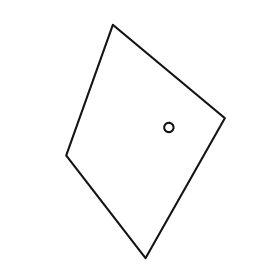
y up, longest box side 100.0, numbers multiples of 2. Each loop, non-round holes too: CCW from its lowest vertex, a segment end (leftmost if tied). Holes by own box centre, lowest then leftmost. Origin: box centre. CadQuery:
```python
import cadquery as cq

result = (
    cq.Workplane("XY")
    .moveTo(0.0, -50.0)
    .lineTo(34.0, 10.0)
    .lineTo(-14.0, 50.0)
    .lineTo(-34.0, -6.0)
    .close()
    .moveTo(10.0, 6.0)
    .circle(2.0)
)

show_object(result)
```